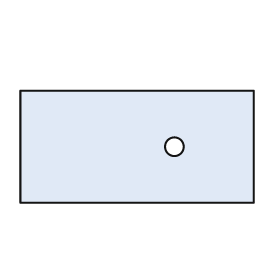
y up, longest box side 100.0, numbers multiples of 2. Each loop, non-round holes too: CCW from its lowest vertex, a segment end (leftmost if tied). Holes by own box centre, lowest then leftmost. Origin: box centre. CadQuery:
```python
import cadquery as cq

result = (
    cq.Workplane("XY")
    .moveTo(-50.0, -24.0)
    .lineTo(50.0, -24.0)
    .lineTo(50.0, 24.0)
    .lineTo(-50.0, 24.0)
    .close()
    .moveTo(16.0, 0.0)
    .circle(4.0)
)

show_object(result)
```